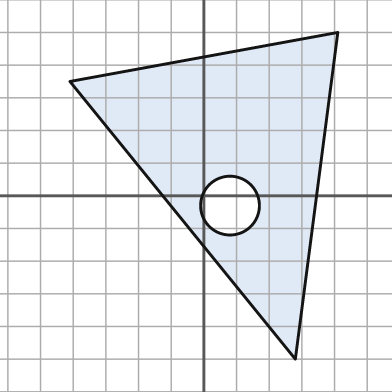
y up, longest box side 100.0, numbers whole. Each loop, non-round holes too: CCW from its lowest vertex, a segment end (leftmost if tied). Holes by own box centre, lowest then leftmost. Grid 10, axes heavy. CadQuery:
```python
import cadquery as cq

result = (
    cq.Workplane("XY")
    .moveTo(28.0, -50.0)
    .lineTo(41.0, 50.0)
    .lineTo(-41.0, 35.0)
    .close()
    .moveTo(8.0, -3.0)
    .circle(9.0)
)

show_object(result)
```